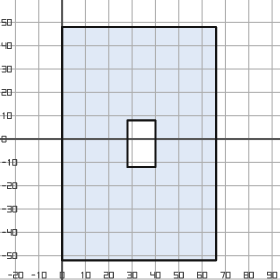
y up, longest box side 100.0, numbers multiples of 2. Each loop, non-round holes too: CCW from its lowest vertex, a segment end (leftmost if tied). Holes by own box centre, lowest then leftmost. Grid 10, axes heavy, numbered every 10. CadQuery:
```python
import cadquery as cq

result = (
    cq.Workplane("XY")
    .moveTo(0.0, -52.0)
    .lineTo(66.0, -52.0)
    .lineTo(66.0, 48.0)
    .lineTo(0.0, 48.0)
    .close()
    .moveTo(28.0, -12.0)
    .lineTo(40.0, -12.0)
    .lineTo(40.0, 8.0)
    .lineTo(28.0, 8.0)
    .close()
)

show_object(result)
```